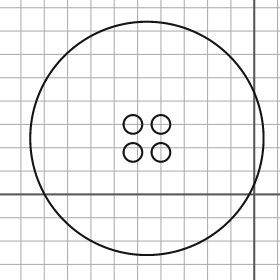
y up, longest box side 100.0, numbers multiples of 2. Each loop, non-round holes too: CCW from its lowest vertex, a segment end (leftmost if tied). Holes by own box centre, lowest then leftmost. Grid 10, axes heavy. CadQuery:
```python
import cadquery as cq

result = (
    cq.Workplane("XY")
    .moveTo(-46.0, 24.0)
    .circle(50.0)
    .moveTo(-52.0, 18.0)
    .circle(4.0)
    .moveTo(-40.0, 18.0)
    .circle(4.0)
    .moveTo(-52.0, 30.0)
    .circle(4.0)
    .moveTo(-40.0, 30.0)
    .circle(4.0)
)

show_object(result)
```